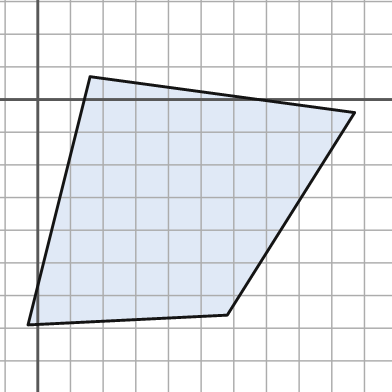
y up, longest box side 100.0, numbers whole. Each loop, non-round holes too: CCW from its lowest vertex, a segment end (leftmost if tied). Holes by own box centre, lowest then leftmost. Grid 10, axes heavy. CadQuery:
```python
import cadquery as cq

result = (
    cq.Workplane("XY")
    .moveTo(-3.0, -69.0)
    .lineTo(58.0, -66.0)
    .lineTo(97.0, -4.0)
    .lineTo(16.0, 7.0)
    .close()
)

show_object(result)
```